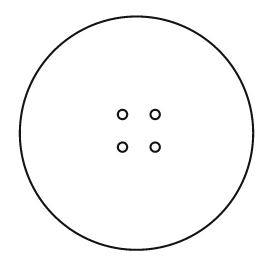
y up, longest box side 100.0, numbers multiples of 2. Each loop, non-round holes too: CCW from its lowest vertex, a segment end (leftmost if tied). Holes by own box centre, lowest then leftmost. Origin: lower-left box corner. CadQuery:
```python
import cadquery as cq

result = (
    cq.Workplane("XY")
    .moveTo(50.0, 50.0)
    .circle(50.0)
    .moveTo(44.0, 44.0)
    .circle(2.0)
    .moveTo(58.0, 44.0)
    .circle(2.0)
    .moveTo(44.0, 58.0)
    .circle(2.0)
    .moveTo(58.0, 58.0)
    .circle(2.0)
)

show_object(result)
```